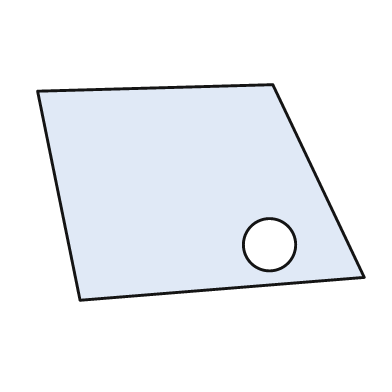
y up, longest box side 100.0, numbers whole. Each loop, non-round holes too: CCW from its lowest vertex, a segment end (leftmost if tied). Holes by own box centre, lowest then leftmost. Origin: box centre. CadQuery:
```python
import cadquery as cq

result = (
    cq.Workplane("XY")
    .moveTo(-37.0, -33.0)
    .lineTo(50.0, -26.0)
    .lineTo(22.0, 33.0)
    .lineTo(-50.0, 31.0)
    .close()
    .moveTo(21.0, -16.0)
    .circle(8.0)
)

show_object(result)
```